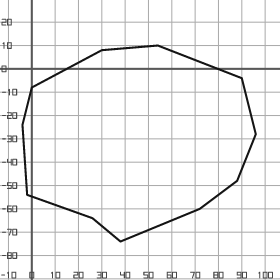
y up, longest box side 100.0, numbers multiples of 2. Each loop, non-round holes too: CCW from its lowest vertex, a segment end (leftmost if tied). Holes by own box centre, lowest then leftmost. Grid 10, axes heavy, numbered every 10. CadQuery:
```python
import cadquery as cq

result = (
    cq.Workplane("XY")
    .moveTo(38.0, -74.0)
    .lineTo(72.0, -60.0)
    .lineTo(88.0, -48.0)
    .lineTo(96.0, -28.0)
    .lineTo(90.0, -4.0)
    .lineTo(54.0, 10.0)
    .lineTo(30.0, 8.0)
    .lineTo(0.0, -8.0)
    .lineTo(-4.0, -24.0)
    .lineTo(-2.0, -54.0)
    .lineTo(26.0, -64.0)
    .close()
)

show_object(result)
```